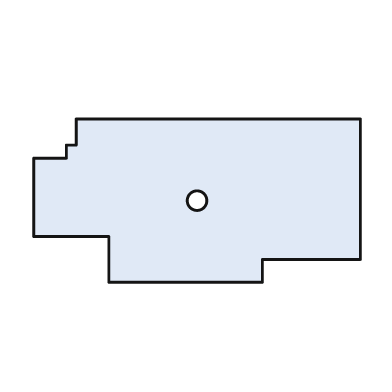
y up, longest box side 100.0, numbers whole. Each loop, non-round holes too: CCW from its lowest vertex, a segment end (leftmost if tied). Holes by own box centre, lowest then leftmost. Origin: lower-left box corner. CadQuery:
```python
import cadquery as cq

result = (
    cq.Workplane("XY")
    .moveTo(23.0, 0.0)
    .lineTo(70.0, 0.0)
    .lineTo(70.0, 7.0)
    .lineTo(100.0, 7.0)
    .lineTo(100.0, 50.0)
    .lineTo(13.0, 50.0)
    .lineTo(13.0, 42.0)
    .lineTo(10.0, 42.0)
    .lineTo(10.0, 38.0)
    .lineTo(0.0, 38.0)
    .lineTo(0.0, 14.0)
    .lineTo(23.0, 14.0)
    .close()
    .moveTo(50.0, 25.0)
    .circle(3.0)
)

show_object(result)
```